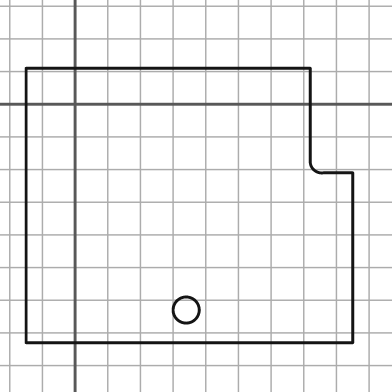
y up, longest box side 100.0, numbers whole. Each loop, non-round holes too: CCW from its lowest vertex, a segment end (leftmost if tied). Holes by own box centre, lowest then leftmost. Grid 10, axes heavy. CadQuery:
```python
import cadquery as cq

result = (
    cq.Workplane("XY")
    .moveTo(-15.0, -73.0)
    .lineTo(85.0, -73.0)
    .lineTo(85.0, -21.0)
    .lineTo(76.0, -21.0)
    .threePointArc((73.0, -20.0), (72.0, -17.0))
    .lineTo(72.0, 11.0)
    .lineTo(-15.0, 11.0)
    .close()
    .moveTo(34.0, -63.0)
    .circle(4.0)
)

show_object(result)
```